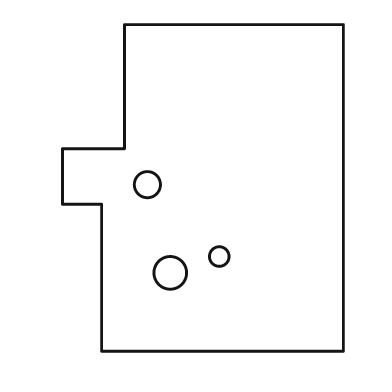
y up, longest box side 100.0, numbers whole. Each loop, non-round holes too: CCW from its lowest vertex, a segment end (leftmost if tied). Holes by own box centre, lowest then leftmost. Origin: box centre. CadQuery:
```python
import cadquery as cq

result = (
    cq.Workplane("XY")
    .moveTo(-31.0, -50.0)
    .lineTo(43.0, -50.0)
    .lineTo(43.0, 50.0)
    .lineTo(-24.0, 50.0)
    .lineTo(-24.0, 12.0)
    .lineTo(-43.0, 12.0)
    .lineTo(-43.0, -5.0)
    .lineTo(-31.0, -5.0)
    .close()
    .moveTo(-10.0, -26.0)
    .circle(5.0)
    .moveTo(5.0, -21.0)
    .circle(3.0)
    .moveTo(-17.0, 1.0)
    .circle(4.0)
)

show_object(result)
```